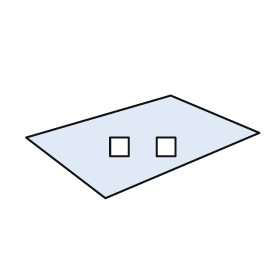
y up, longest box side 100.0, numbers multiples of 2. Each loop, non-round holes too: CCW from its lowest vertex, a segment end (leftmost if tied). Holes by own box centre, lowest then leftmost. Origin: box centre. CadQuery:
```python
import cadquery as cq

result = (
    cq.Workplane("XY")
    .moveTo(-16.0, -22.0)
    .lineTo(50.0, 6.0)
    .lineTo(12.0, 22.0)
    .lineTo(-50.0, 4.0)
    .close()
    .moveTo(-14.0, -4.0)
    .lineTo(-6.0, -4.0)
    .lineTo(-6.0, 4.0)
    .lineTo(-14.0, 4.0)
    .close()
    .moveTo(6.0, -4.0)
    .lineTo(14.0, -4.0)
    .lineTo(14.0, 4.0)
    .lineTo(6.0, 4.0)
    .close()
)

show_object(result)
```